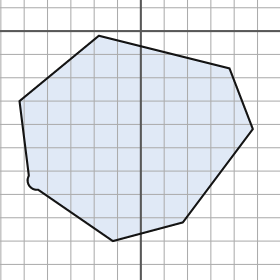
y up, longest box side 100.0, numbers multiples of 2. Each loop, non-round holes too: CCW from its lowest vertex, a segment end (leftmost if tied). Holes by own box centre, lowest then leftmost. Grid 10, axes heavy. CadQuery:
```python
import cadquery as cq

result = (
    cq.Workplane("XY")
    .moveTo(-12.0, -90.0)
    .lineTo(18.0, -82.0)
    .lineTo(48.0, -42.0)
    .lineTo(38.0, -16.0)
    .lineTo(-18.0, -2.0)
    .lineTo(-52.0, -30.0)
    .lineTo(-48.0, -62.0)
    .threePointArc((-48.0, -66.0), (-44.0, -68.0))
    .close()
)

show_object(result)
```